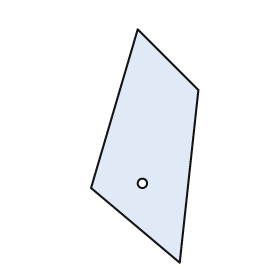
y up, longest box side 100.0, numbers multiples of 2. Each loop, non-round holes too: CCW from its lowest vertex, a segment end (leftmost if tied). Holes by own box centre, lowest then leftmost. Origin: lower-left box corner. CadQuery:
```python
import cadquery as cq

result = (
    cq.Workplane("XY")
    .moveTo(38.0, 0.0)
    .lineTo(46.0, 74.0)
    .lineTo(20.0, 100.0)
    .lineTo(0.0, 32.0)
    .close()
    .moveTo(22.0, 34.0)
    .circle(2.0)
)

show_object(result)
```